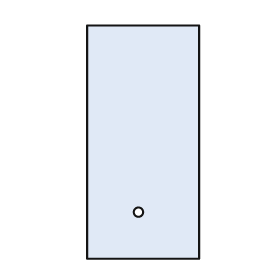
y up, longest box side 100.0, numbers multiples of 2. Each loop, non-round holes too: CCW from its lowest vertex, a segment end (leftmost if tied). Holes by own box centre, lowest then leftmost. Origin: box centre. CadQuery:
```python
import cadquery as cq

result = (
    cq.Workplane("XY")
    .moveTo(-24.0, -50.0)
    .lineTo(24.0, -50.0)
    .lineTo(24.0, 50.0)
    .lineTo(-24.0, 50.0)
    .close()
    .moveTo(-2.0, -30.0)
    .circle(2.0)
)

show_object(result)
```